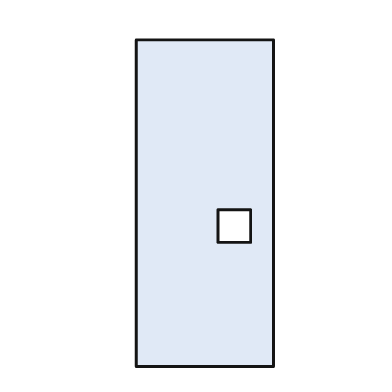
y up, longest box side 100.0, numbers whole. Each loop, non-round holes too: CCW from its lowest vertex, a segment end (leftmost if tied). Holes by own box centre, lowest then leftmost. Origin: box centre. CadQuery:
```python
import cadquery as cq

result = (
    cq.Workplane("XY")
    .moveTo(-21.0, -50.0)
    .lineTo(21.0, -50.0)
    .lineTo(21.0, 50.0)
    .lineTo(-21.0, 50.0)
    .close()
    .moveTo(4.0, -12.0)
    .lineTo(14.0, -12.0)
    .lineTo(14.0, -2.0)
    .lineTo(4.0, -2.0)
    .close()
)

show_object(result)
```